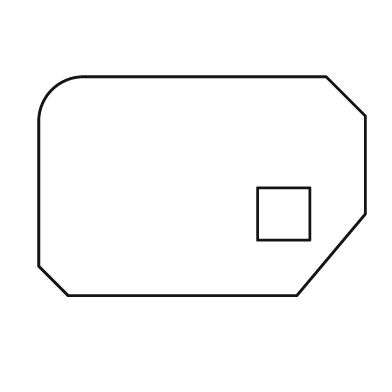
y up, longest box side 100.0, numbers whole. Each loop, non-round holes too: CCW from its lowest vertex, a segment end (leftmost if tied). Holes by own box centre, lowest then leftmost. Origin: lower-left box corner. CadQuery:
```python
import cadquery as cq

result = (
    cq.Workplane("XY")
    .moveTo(9.0, 0.0)
    .lineTo(79.0, 0.0)
    .lineTo(100.0, 25.0)
    .lineTo(100.0, 55.0)
    .lineTo(88.0, 67.0)
    .lineTo(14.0, 67.0)
    .threePointArc((4.0, 63.0), (0.0, 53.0))
    .lineTo(0.0, 9.0)
    .close()
    .moveTo(67.0, 17.0)
    .lineTo(83.0, 17.0)
    .lineTo(83.0, 33.0)
    .lineTo(67.0, 33.0)
    .close()
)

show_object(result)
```